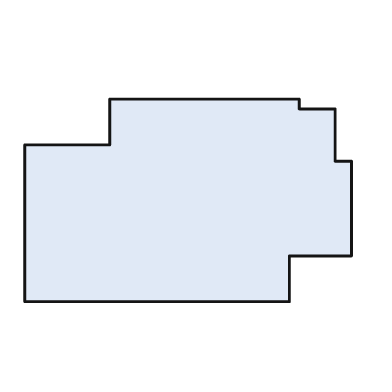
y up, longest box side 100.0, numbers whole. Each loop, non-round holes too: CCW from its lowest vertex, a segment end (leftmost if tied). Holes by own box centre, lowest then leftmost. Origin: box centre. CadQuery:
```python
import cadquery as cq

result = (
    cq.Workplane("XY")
    .moveTo(-50.0, -31.0)
    .lineTo(31.0, -31.0)
    .lineTo(31.0, -17.0)
    .lineTo(50.0, -17.0)
    .lineTo(50.0, 12.0)
    .lineTo(45.0, 12.0)
    .lineTo(45.0, 28.0)
    .lineTo(34.0, 28.0)
    .lineTo(34.0, 31.0)
    .lineTo(-24.0, 31.0)
    .lineTo(-24.0, 17.0)
    .lineTo(-50.0, 17.0)
    .close()
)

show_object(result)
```